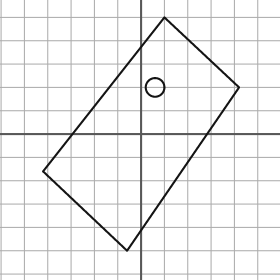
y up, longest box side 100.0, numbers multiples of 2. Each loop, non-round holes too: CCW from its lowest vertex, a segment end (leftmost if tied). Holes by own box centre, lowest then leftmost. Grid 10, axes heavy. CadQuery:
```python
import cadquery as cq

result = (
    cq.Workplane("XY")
    .moveTo(-6.0, -50.0)
    .lineTo(42.0, 20.0)
    .lineTo(10.0, 50.0)
    .lineTo(-42.0, -16.0)
    .close()
    .moveTo(6.0, 20.0)
    .circle(4.0)
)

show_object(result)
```